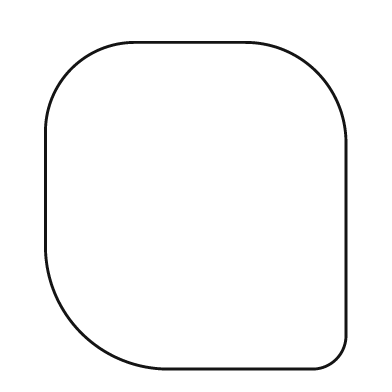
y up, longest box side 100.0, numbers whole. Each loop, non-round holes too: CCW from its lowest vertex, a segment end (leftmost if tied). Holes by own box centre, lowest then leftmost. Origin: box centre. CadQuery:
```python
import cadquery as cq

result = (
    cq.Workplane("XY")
    .moveTo(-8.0, -50.0)
    .lineTo(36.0, -50.0)
    .threePointArc((43.0, -47.0), (46.0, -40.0))
    .lineTo(46.0, 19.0)
    .threePointArc((37.0, 41.0), (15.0, 50.0))
    .lineTo(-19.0, 50.0)
    .threePointArc((-38.0, 42.0), (-46.0, 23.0))
    .lineTo(-46.0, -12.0)
    .threePointArc((-35.0, -39.0), (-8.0, -50.0))
    .close()
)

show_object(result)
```